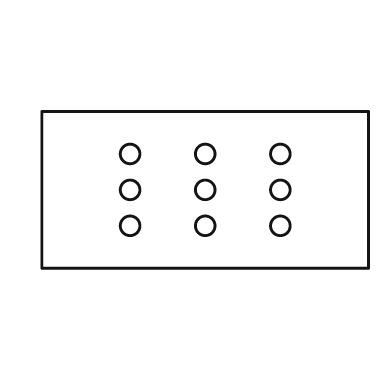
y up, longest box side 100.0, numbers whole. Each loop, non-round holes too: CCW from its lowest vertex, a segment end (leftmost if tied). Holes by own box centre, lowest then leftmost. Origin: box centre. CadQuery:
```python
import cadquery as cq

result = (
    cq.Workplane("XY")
    .moveTo(-50.0, -24.0)
    .lineTo(50.0, -24.0)
    .lineTo(50.0, 24.0)
    .lineTo(-50.0, 24.0)
    .close()
    .moveTo(-23.0, -11.0)
    .circle(3.0)
    .moveTo(0.0, -11.0)
    .circle(3.0)
    .moveTo(23.0, -11.0)
    .circle(3.0)
    .moveTo(-23.0, 0.0)
    .circle(3.0)
    .moveTo(0.0, 0.0)
    .circle(3.0)
    .moveTo(23.0, 0.0)
    .circle(3.0)
    .moveTo(-23.0, 11.0)
    .circle(3.0)
    .moveTo(0.0, 11.0)
    .circle(3.0)
    .moveTo(23.0, 11.0)
    .circle(3.0)
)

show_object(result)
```